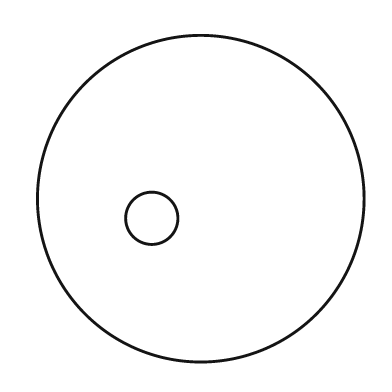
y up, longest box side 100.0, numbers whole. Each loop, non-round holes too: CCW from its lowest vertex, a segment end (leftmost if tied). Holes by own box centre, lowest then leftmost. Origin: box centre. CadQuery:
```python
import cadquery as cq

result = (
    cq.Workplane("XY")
    .moveTo(0.0, 0.0)
    .circle(50.0)
    .moveTo(-15.0, -6.0)
    .circle(8.0)
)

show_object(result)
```